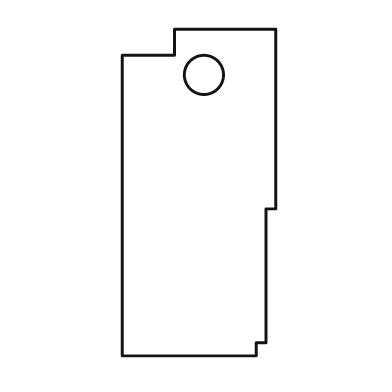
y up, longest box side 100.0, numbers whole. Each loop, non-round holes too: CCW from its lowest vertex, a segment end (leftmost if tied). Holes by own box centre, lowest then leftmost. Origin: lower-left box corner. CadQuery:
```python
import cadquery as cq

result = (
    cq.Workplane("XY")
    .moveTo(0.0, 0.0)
    .lineTo(41.0, 0.0)
    .lineTo(41.0, 4.0)
    .lineTo(44.0, 4.0)
    .lineTo(44.0, 45.0)
    .lineTo(47.0, 45.0)
    .lineTo(47.0, 100.0)
    .lineTo(16.0, 100.0)
    .lineTo(16.0, 92.0)
    .lineTo(0.0, 92.0)
    .close()
    .moveTo(25.0, 86.0)
    .circle(6.0)
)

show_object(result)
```